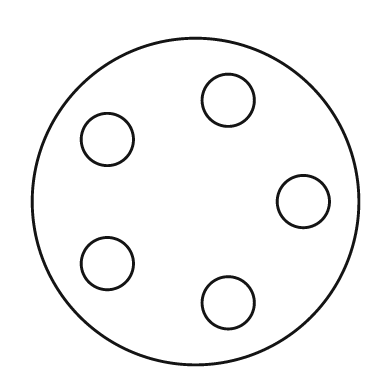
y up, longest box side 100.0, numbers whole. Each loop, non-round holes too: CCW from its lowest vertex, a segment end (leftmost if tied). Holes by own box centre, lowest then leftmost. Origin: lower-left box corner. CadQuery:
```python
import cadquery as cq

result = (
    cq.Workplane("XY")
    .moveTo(50.0, 50.0)
    .circle(50.0)
    .moveTo(60.0, 19.0)
    .circle(8.0)
    .moveTo(23.0, 31.0)
    .circle(8.0)
    .moveTo(83.0, 50.0)
    .circle(8.0)
    .moveTo(23.0, 69.0)
    .circle(8.0)
    .moveTo(60.0, 81.0)
    .circle(8.0)
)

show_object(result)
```